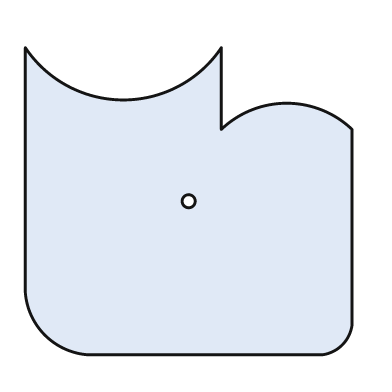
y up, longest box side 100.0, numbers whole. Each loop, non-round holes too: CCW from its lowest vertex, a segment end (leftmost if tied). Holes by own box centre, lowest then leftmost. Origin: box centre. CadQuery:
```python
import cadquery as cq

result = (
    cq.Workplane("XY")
    .moveTo(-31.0, -47.0)
    .lineTo(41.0, -47.0)
    .threePointArc((47.0, -44.0), (50.0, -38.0))
    .lineTo(50.0, 22.0)
    .threePointArc((30.0, 30.0), (10.0, 22.0))
    .lineTo(10.0, 47.0)
    .threePointArc((-20.0, 31.0), (-50.0, 47.0))
    .lineTo(-50.0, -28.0)
    .threePointArc((-44.0, -41.0), (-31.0, -47.0))
    .close()
    .moveTo(0.0, 0.0)
    .circle(2.0)
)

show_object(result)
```